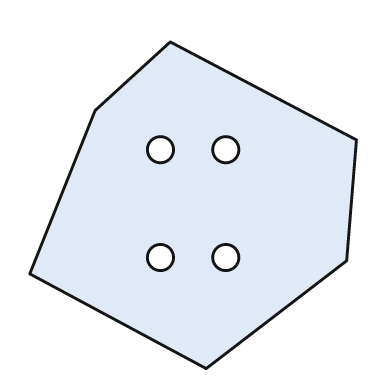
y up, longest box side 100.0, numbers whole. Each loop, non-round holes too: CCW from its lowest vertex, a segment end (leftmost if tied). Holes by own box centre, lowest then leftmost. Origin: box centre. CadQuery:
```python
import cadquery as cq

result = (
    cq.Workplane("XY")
    .moveTo(4.0, -50.0)
    .lineTo(47.0, -17.0)
    .lineTo(50.0, 20.0)
    .lineTo(-7.0, 50.0)
    .lineTo(-30.0, 29.0)
    .lineTo(-50.0, -21.0)
    .close()
    .moveTo(-10.0, -16.0)
    .circle(4.0)
    .moveTo(10.0, -16.0)
    .circle(4.0)
    .moveTo(-10.0, 17.0)
    .circle(4.0)
    .moveTo(10.0, 17.0)
    .circle(4.0)
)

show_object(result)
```